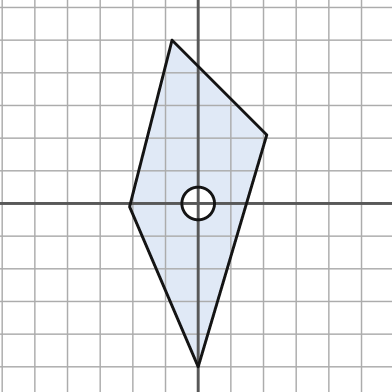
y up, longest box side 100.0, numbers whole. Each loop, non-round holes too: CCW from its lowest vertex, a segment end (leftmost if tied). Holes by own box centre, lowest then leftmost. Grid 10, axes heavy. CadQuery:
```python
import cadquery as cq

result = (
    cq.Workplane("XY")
    .moveTo(0.0, -50.0)
    .lineTo(21.0, 21.0)
    .lineTo(-8.0, 50.0)
    .lineTo(-21.0, -1.0)
    .close()
    .moveTo(0.0, 0.0)
    .circle(5.0)
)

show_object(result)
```